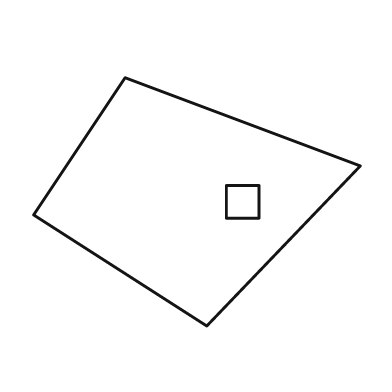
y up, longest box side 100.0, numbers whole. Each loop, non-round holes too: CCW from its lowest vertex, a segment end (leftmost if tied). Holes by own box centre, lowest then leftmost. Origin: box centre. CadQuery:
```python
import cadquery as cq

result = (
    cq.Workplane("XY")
    .moveTo(3.0, -38.0)
    .lineTo(50.0, 11.0)
    .lineTo(-22.0, 38.0)
    .lineTo(-50.0, -4.0)
    .close()
    .moveTo(9.0, -5.0)
    .lineTo(19.0, -5.0)
    .lineTo(19.0, 5.0)
    .lineTo(9.0, 5.0)
    .close()
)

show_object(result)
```